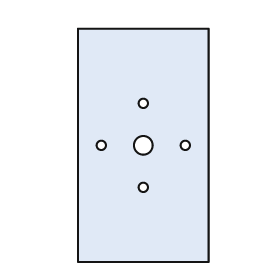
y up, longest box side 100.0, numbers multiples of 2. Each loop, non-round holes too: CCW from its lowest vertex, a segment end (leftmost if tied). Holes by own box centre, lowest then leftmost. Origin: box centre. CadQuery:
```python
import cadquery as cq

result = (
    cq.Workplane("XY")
    .moveTo(-28.0, -50.0)
    .lineTo(28.0, -50.0)
    .lineTo(28.0, 50.0)
    .lineTo(-28.0, 50.0)
    .close()
    .moveTo(0.0, -18.0)
    .circle(2.0)
    .moveTo(-18.0, 0.0)
    .circle(2.0)
    .moveTo(0.0, 0.0)
    .circle(4.0)
    .moveTo(18.0, 0.0)
    .circle(2.0)
    .moveTo(0.0, 18.0)
    .circle(2.0)
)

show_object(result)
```